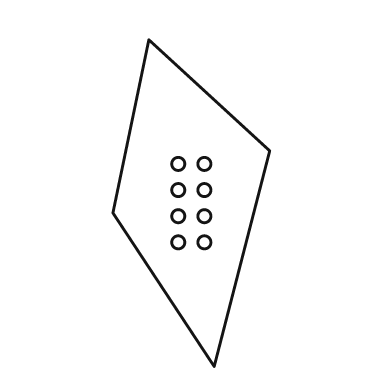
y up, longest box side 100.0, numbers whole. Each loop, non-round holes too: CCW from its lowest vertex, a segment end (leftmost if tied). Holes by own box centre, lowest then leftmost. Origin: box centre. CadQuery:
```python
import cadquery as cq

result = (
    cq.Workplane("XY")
    .moveTo(7.0, -50.0)
    .lineTo(24.0, 16.0)
    .lineTo(-13.0, 50.0)
    .lineTo(-24.0, -3.0)
    .close()
    .moveTo(-4.0, -12.0)
    .circle(2.0)
    .moveTo(4.0, -12.0)
    .circle(2.0)
    .moveTo(-4.0, -4.0)
    .circle(2.0)
    .moveTo(4.0, -4.0)
    .circle(2.0)
    .moveTo(-4.0, 4.0)
    .circle(2.0)
    .moveTo(4.0, 4.0)
    .circle(2.0)
    .moveTo(-4.0, 12.0)
    .circle(2.0)
    .moveTo(4.0, 12.0)
    .circle(2.0)
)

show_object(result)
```